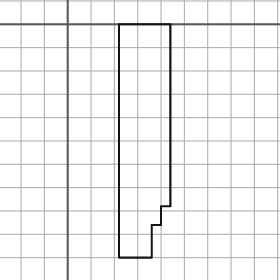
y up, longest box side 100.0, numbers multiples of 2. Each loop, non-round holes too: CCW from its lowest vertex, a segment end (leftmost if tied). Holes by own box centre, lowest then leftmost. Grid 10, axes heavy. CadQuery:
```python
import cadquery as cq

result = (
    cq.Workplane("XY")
    .moveTo(22.0, -100.0)
    .lineTo(36.0, -100.0)
    .lineTo(36.0, -86.0)
    .lineTo(40.0, -86.0)
    .lineTo(40.0, -78.0)
    .lineTo(44.0, -78.0)
    .lineTo(44.0, 0.0)
    .lineTo(22.0, 0.0)
    .close()
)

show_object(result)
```